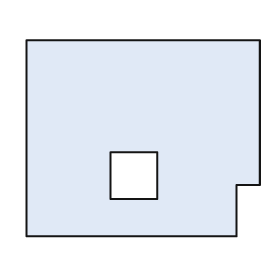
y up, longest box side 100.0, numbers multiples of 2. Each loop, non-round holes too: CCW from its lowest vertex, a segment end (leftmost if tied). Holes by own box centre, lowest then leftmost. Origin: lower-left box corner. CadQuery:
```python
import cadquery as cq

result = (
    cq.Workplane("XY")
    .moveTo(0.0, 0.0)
    .lineTo(90.0, 0.0)
    .lineTo(90.0, 22.0)
    .lineTo(100.0, 22.0)
    .lineTo(100.0, 84.0)
    .lineTo(0.0, 84.0)
    .close()
    .moveTo(36.0, 16.0)
    .lineTo(56.0, 16.0)
    .lineTo(56.0, 36.0)
    .lineTo(36.0, 36.0)
    .close()
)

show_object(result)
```